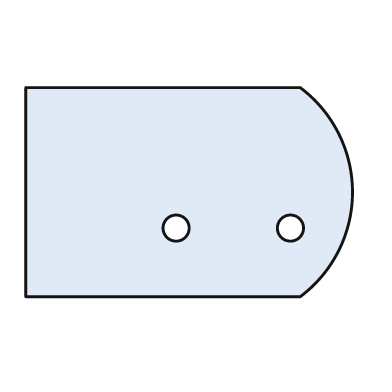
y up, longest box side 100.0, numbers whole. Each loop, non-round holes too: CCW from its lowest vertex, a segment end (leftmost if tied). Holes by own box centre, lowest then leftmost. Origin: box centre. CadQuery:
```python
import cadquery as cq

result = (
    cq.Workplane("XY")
    .moveTo(-50.0, -32.0)
    .lineTo(34.0, -32.0)
    .threePointArc((50.0, 0.0), (34.0, 32.0))
    .lineTo(-50.0, 32.0)
    .close()
    .moveTo(-4.0, -11.0)
    .circle(4.0)
    .moveTo(31.0, -11.0)
    .circle(4.0)
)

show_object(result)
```